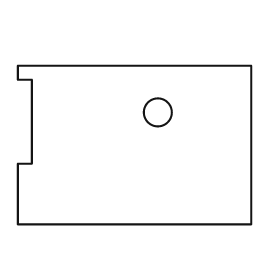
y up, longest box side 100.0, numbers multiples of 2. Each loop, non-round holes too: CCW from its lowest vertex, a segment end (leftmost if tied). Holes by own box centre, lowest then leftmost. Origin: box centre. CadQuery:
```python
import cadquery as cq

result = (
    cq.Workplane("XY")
    .moveTo(-50.0, -34.0)
    .lineTo(50.0, -34.0)
    .lineTo(50.0, 34.0)
    .lineTo(-50.0, 34.0)
    .lineTo(-50.0, 28.0)
    .lineTo(-44.0, 28.0)
    .lineTo(-44.0, -8.0)
    .lineTo(-50.0, -8.0)
    .close()
    .moveTo(10.0, 14.0)
    .circle(6.0)
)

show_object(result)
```